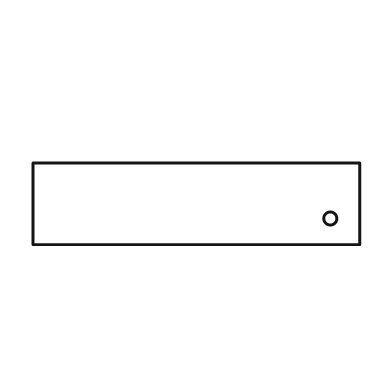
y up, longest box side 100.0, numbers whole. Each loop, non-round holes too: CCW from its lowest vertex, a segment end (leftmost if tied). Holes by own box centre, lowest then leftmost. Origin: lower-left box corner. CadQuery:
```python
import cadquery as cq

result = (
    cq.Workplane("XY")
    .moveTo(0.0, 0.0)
    .lineTo(100.0, 0.0)
    .lineTo(100.0, 25.0)
    .lineTo(0.0, 25.0)
    .close()
    .moveTo(91.0, 8.0)
    .circle(2.0)
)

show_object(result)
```